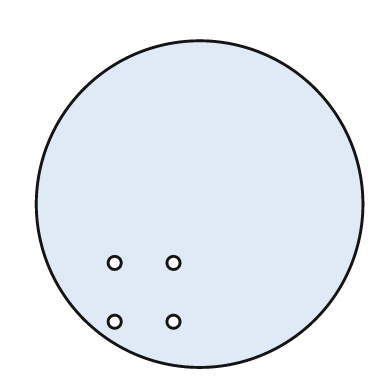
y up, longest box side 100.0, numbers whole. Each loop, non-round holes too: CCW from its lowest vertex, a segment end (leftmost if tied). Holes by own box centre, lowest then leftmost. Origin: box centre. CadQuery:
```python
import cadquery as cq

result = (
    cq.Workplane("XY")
    .moveTo(0.0, 0.0)
    .circle(50.0)
    .moveTo(-26.0, -36.0)
    .circle(2.0)
    .moveTo(-8.0, -36.0)
    .circle(2.0)
    .moveTo(-26.0, -18.0)
    .circle(2.0)
    .moveTo(-8.0, -18.0)
    .circle(2.0)
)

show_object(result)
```